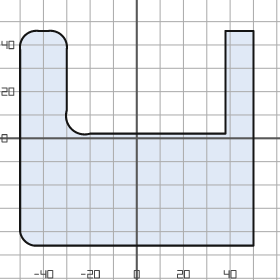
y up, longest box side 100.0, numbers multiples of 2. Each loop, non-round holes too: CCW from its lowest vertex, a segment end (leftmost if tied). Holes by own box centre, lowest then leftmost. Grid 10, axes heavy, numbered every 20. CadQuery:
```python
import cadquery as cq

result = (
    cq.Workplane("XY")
    .moveTo(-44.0, -46.0)
    .lineTo(50.0, -46.0)
    .lineTo(50.0, 46.0)
    .lineTo(38.0, 46.0)
    .lineTo(38.0, 2.0)
    .lineTo(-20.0, 2.0)
    .threePointArc((-28.0, 4.0), (-30.0, 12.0))
    .lineTo(-30.0, 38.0)
    .threePointArc((-32.0, 44.0), (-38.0, 46.0))
    .lineTo(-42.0, 46.0)
    .threePointArc((-48.0, 44.0), (-50.0, 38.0))
    .lineTo(-50.0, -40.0)
    .threePointArc((-48.0, -44.0), (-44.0, -46.0))
    .close()
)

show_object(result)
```